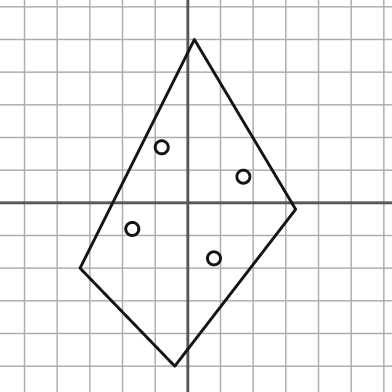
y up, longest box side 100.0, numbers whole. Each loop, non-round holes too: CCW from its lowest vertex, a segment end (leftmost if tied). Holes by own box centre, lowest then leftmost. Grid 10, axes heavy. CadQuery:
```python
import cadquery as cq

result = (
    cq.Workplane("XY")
    .moveTo(-4.0, -50.0)
    .lineTo(33.0, -2.0)
    .lineTo(2.0, 50.0)
    .lineTo(-33.0, -20.0)
    .close()
    .moveTo(8.0, -17.0)
    .circle(2.0)
    .moveTo(-17.0, -8.0)
    .circle(2.0)
    .moveTo(17.0, 8.0)
    .circle(2.0)
    .moveTo(-8.0, 17.0)
    .circle(2.0)
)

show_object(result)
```